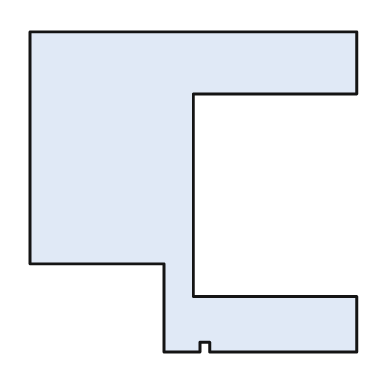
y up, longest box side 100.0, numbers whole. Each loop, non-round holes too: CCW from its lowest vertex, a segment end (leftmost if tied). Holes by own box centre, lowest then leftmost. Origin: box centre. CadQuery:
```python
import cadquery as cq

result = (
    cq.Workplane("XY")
    .moveTo(-9.0, -49.0)
    .lineTo(2.0, -49.0)
    .lineTo(2.0, -46.0)
    .lineTo(5.0, -46.0)
    .lineTo(5.0, -49.0)
    .lineTo(50.0, -49.0)
    .lineTo(50.0, -32.0)
    .lineTo(0.0, -32.0)
    .lineTo(0.0, 30.0)
    .lineTo(50.0, 30.0)
    .lineTo(50.0, 49.0)
    .lineTo(-50.0, 49.0)
    .lineTo(-50.0, -22.0)
    .lineTo(-9.0, -22.0)
    .close()
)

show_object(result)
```